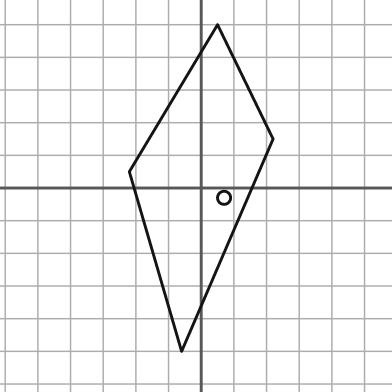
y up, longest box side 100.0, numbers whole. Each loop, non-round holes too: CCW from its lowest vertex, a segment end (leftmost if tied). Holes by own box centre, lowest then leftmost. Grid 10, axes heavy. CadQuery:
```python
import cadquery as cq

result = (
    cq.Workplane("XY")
    .moveTo(-6.0, -50.0)
    .lineTo(22.0, 15.0)
    .lineTo(5.0, 50.0)
    .lineTo(-22.0, 5.0)
    .close()
    .moveTo(7.0, -3.0)
    .circle(2.0)
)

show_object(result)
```